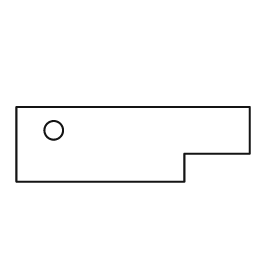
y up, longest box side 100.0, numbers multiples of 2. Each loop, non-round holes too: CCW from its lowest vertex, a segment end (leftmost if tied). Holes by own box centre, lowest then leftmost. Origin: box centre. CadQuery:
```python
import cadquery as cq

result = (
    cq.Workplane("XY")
    .moveTo(-50.0, -16.0)
    .lineTo(22.0, -16.0)
    .lineTo(22.0, -4.0)
    .lineTo(50.0, -4.0)
    .lineTo(50.0, 16.0)
    .lineTo(-50.0, 16.0)
    .close()
    .moveTo(-34.0, 6.0)
    .circle(4.0)
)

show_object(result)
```